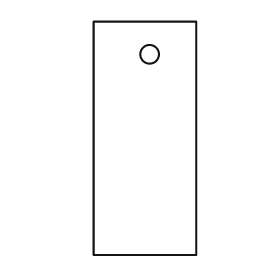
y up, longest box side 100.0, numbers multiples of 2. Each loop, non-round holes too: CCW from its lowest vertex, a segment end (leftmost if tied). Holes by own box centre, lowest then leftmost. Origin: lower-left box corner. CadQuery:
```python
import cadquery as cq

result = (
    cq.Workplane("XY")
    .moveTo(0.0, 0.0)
    .lineTo(44.0, 0.0)
    .lineTo(44.0, 100.0)
    .lineTo(0.0, 100.0)
    .close()
    .moveTo(24.0, 86.0)
    .circle(4.0)
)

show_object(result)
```